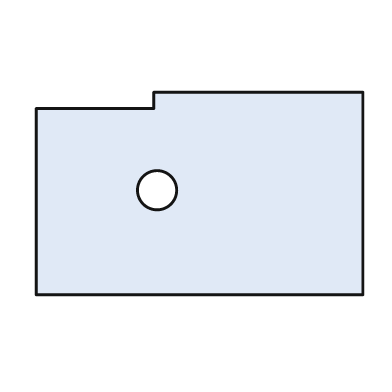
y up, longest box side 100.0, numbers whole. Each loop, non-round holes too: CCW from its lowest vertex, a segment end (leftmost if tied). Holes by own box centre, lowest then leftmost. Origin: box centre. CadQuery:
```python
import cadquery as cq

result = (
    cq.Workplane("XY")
    .moveTo(-50.0, -31.0)
    .lineTo(50.0, -31.0)
    .lineTo(50.0, 31.0)
    .lineTo(-14.0, 31.0)
    .lineTo(-14.0, 26.0)
    .lineTo(-50.0, 26.0)
    .close()
    .moveTo(-13.0, 1.0)
    .circle(6.0)
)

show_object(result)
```